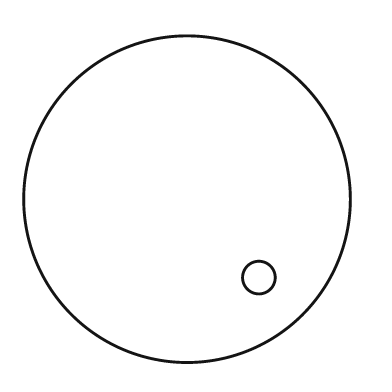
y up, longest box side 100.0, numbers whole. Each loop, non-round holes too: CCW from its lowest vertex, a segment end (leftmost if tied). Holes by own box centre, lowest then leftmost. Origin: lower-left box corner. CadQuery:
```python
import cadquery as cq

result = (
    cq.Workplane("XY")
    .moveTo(50.0, 50.0)
    .circle(50.0)
    .moveTo(72.0, 26.0)
    .circle(5.0)
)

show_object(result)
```